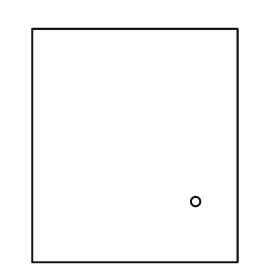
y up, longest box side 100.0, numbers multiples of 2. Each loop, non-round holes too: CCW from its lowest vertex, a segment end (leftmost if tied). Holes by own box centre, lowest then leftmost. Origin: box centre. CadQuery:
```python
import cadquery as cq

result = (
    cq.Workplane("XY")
    .moveTo(-44.0, -50.0)
    .lineTo(44.0, -50.0)
    .lineTo(44.0, 50.0)
    .lineTo(-44.0, 50.0)
    .close()
    .moveTo(26.0, -24.0)
    .circle(2.0)
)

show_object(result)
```